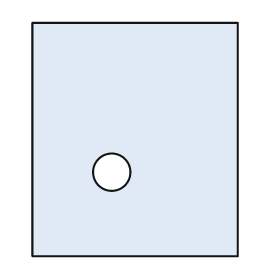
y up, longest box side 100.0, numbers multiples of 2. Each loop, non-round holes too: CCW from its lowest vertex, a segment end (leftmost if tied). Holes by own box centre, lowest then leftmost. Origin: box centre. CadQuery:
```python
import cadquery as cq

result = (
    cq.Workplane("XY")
    .moveTo(-44.0, -50.0)
    .lineTo(44.0, -50.0)
    .lineTo(44.0, 50.0)
    .lineTo(-44.0, 50.0)
    .close()
    .moveTo(-10.0, -14.0)
    .circle(8.0)
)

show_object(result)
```